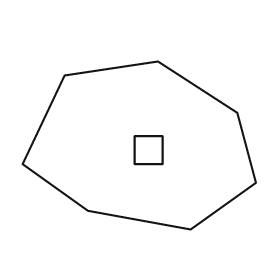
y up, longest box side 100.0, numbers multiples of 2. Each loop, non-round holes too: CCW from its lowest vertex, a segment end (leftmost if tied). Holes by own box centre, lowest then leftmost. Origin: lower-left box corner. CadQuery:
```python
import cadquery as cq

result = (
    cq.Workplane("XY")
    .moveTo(72.0, 0.0)
    .lineTo(100.0, 20.0)
    .lineTo(92.0, 50.0)
    .lineTo(58.0, 72.0)
    .lineTo(18.0, 66.0)
    .lineTo(0.0, 28.0)
    .lineTo(28.0, 8.0)
    .close()
    .moveTo(48.0, 28.0)
    .lineTo(60.0, 28.0)
    .lineTo(60.0, 40.0)
    .lineTo(48.0, 40.0)
    .close()
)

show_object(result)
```